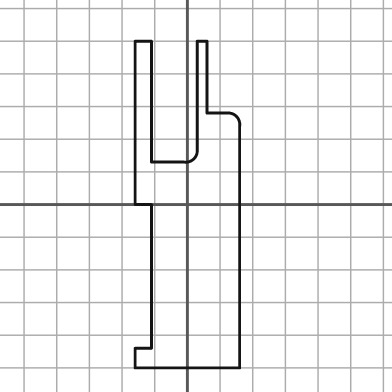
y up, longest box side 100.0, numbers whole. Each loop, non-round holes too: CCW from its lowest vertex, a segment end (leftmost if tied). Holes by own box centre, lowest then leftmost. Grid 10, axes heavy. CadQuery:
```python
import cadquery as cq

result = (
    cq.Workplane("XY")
    .moveTo(-16.0, -50.0)
    .lineTo(16.0, -50.0)
    .lineTo(16.0, 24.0)
    .threePointArc((15.0, 27.0), (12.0, 28.0))
    .lineTo(6.0, 28.0)
    .lineTo(6.0, 50.0)
    .lineTo(3.0, 50.0)
    .lineTo(3.0, 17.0)
    .threePointArc((2.0, 14.0), (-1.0, 13.0))
    .lineTo(-11.0, 13.0)
    .lineTo(-11.0, 50.0)
    .lineTo(-16.0, 50.0)
    .lineTo(-16.0, 0.0)
    .lineTo(-11.0, 0.0)
    .lineTo(-11.0, -44.0)
    .lineTo(-16.0, -44.0)
    .close()
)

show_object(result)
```